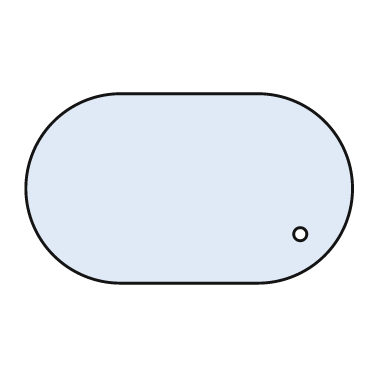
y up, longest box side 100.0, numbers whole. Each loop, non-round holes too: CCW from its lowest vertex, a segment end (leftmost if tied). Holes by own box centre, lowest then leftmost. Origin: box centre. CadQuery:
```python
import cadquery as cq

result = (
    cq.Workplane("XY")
    .moveTo(-21.0, -29.0)
    .lineTo(21.0, -29.0)
    .threePointArc((50.0, 0.0), (21.0, 29.0))
    .lineTo(-21.0, 29.0)
    .threePointArc((-50.0, 0.0), (-21.0, -29.0))
    .close()
    .moveTo(34.0, -14.0)
    .circle(2.0)
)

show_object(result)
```